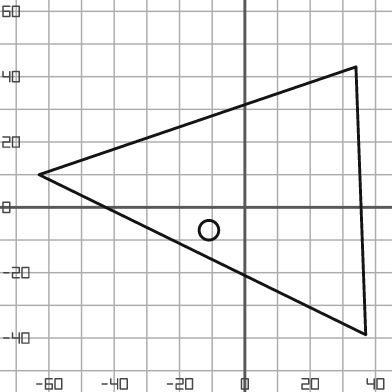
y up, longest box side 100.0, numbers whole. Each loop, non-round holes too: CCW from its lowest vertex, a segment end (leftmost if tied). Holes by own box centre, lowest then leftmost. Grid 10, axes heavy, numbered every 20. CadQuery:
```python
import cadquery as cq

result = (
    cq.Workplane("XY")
    .moveTo(37.0, -39.0)
    .lineTo(34.0, 43.0)
    .lineTo(-63.0, 10.0)
    .close()
    .moveTo(-11.0, -7.0)
    .circle(3.0)
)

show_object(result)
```